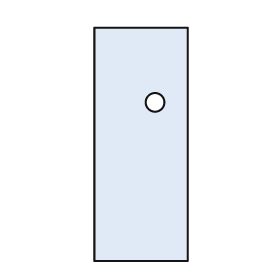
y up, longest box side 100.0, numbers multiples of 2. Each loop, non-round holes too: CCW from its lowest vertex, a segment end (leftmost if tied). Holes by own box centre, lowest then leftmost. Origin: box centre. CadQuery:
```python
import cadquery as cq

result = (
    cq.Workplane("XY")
    .moveTo(-20.0, -50.0)
    .lineTo(20.0, -50.0)
    .lineTo(20.0, 50.0)
    .lineTo(-20.0, 50.0)
    .close()
    .moveTo(6.0, 18.0)
    .circle(4.0)
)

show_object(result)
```